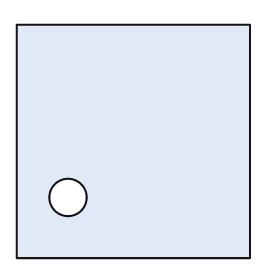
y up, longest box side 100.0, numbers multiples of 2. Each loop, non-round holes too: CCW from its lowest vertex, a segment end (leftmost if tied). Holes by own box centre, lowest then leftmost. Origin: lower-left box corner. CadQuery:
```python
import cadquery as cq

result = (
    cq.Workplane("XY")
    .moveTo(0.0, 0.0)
    .lineTo(100.0, 0.0)
    .lineTo(100.0, 100.0)
    .lineTo(0.0, 100.0)
    .close()
    .moveTo(22.0, 26.0)
    .circle(8.0)
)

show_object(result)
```